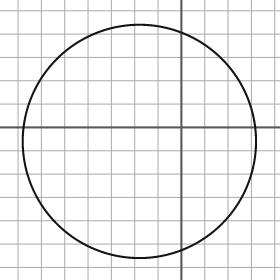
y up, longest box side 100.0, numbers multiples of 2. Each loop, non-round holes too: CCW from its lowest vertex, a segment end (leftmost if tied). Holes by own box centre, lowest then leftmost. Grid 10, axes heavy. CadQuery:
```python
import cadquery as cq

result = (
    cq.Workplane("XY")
    .moveTo(-18.0, -6.0)
    .circle(50.0)
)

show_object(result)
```